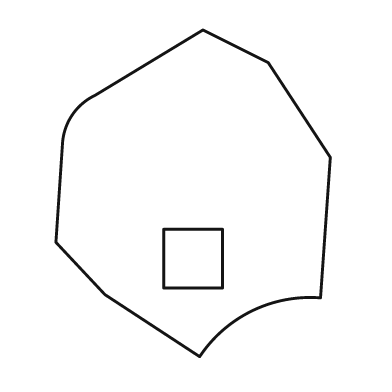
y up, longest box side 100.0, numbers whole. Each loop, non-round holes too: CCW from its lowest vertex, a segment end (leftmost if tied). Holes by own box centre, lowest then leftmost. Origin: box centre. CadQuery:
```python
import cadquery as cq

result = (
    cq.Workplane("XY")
    .moveTo(2.0, -50.0)
    .threePointArc((18.0, -36.0), (39.0, -32.0))
    .lineTo(42.0, 11.0)
    .lineTo(23.0, 40.0)
    .lineTo(3.0, 50.0)
    .lineTo(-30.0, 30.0)
    .threePointArc((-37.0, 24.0), (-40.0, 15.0))
    .lineTo(-42.0, -15.0)
    .lineTo(-27.0, -31.0)
    .close()
    .moveTo(-9.0, -29.0)
    .lineTo(9.0, -29.0)
    .lineTo(9.0, -11.0)
    .lineTo(-9.0, -11.0)
    .close()
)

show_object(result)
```